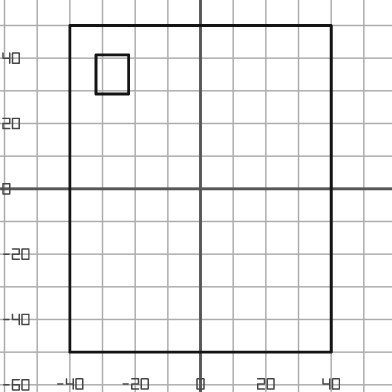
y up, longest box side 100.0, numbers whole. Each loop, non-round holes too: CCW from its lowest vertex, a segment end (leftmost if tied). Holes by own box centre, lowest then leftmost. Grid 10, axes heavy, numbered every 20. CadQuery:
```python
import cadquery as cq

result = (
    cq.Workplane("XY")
    .moveTo(-40.0, -50.0)
    .lineTo(40.0, -50.0)
    .lineTo(40.0, 50.0)
    .lineTo(-40.0, 50.0)
    .close()
    .moveTo(-32.0, 29.0)
    .lineTo(-22.0, 29.0)
    .lineTo(-22.0, 41.0)
    .lineTo(-32.0, 41.0)
    .close()
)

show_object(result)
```